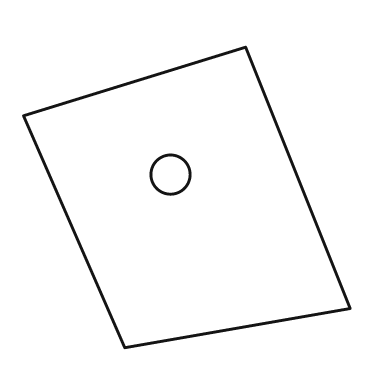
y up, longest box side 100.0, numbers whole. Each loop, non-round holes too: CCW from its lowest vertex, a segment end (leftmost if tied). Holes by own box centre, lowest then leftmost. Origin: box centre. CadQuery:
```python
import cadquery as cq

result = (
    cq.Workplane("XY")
    .moveTo(-19.0, -46.0)
    .lineTo(50.0, -34.0)
    .lineTo(18.0, 46.0)
    .lineTo(-50.0, 25.0)
    .close()
    .moveTo(-5.0, 7.0)
    .circle(6.0)
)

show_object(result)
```